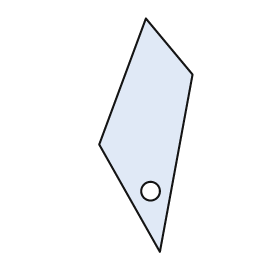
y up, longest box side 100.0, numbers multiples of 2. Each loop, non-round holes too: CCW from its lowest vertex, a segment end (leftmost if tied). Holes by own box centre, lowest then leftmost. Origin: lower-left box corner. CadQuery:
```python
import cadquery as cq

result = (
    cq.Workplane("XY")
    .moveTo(26.0, 0.0)
    .lineTo(40.0, 76.0)
    .lineTo(20.0, 100.0)
    .lineTo(0.0, 46.0)
    .close()
    .moveTo(22.0, 26.0)
    .circle(4.0)
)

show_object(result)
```